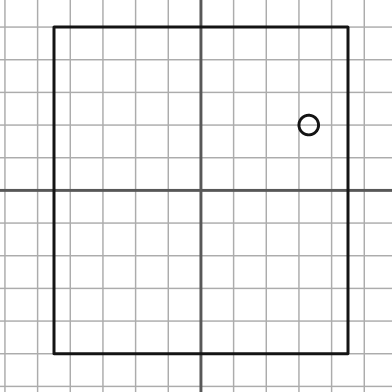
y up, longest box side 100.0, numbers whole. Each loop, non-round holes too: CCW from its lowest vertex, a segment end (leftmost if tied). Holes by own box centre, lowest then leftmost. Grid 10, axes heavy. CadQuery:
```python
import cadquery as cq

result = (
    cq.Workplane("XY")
    .moveTo(-45.0, -50.0)
    .lineTo(45.0, -50.0)
    .lineTo(45.0, 50.0)
    .lineTo(-45.0, 50.0)
    .close()
    .moveTo(33.0, 20.0)
    .circle(3.0)
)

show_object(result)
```